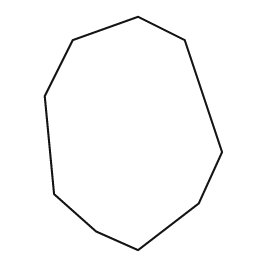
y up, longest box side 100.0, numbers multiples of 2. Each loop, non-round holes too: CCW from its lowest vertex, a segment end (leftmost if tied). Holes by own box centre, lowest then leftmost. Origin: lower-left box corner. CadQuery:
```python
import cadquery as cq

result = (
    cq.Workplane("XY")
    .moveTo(40.0, 0.0)
    .lineTo(66.0, 20.0)
    .lineTo(76.0, 42.0)
    .lineTo(60.0, 90.0)
    .lineTo(40.0, 100.0)
    .lineTo(12.0, 90.0)
    .lineTo(0.0, 66.0)
    .lineTo(4.0, 24.0)
    .lineTo(22.0, 8.0)
    .close()
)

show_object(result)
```